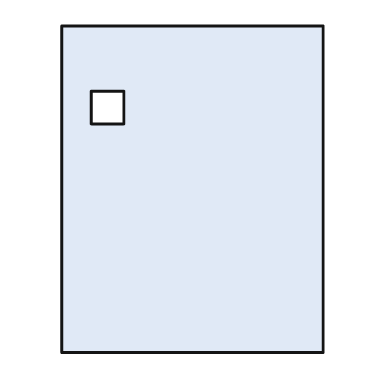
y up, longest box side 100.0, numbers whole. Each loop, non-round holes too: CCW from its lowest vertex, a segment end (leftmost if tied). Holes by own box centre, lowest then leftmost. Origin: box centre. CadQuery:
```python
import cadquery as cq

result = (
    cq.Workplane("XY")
    .moveTo(-40.0, -50.0)
    .lineTo(40.0, -50.0)
    .lineTo(40.0, 50.0)
    .lineTo(-40.0, 50.0)
    .close()
    .moveTo(-31.0, 20.0)
    .lineTo(-21.0, 20.0)
    .lineTo(-21.0, 30.0)
    .lineTo(-31.0, 30.0)
    .close()
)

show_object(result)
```